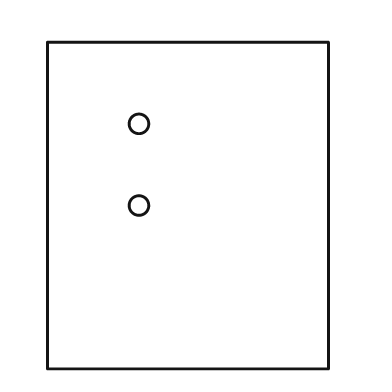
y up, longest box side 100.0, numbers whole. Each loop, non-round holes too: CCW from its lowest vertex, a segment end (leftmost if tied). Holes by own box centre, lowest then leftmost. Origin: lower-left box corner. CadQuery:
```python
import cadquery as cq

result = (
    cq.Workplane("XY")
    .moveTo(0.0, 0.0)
    .lineTo(86.0, 0.0)
    .lineTo(86.0, 100.0)
    .lineTo(0.0, 100.0)
    .close()
    .moveTo(28.0, 50.0)
    .circle(3.0)
    .moveTo(28.0, 75.0)
    .circle(3.0)
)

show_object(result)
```